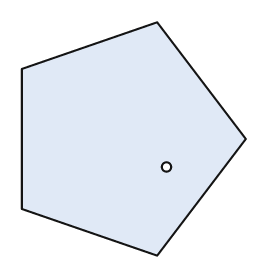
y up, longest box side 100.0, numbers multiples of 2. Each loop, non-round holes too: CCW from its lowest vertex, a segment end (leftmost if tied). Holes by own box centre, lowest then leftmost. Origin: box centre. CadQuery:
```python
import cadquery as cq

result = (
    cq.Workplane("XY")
    .moveTo(10.0, -50.0)
    .lineTo(48.0, 0.0)
    .lineTo(10.0, 50.0)
    .lineTo(-48.0, 30.0)
    .lineTo(-48.0, -30.0)
    .close()
    .moveTo(14.0, -12.0)
    .circle(2.0)
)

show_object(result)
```